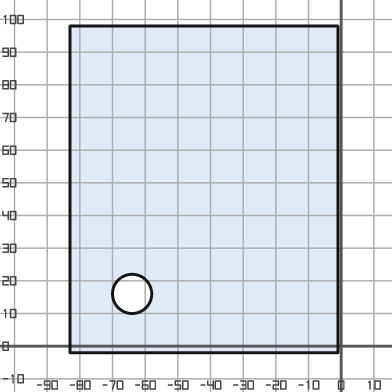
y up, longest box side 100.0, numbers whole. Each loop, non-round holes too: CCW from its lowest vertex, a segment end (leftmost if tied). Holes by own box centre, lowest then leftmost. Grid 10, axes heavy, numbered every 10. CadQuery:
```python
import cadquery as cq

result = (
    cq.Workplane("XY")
    .moveTo(-83.0, -2.0)
    .lineTo(-1.0, -2.0)
    .lineTo(-1.0, 98.0)
    .lineTo(-83.0, 98.0)
    .close()
    .moveTo(-64.0, 16.0)
    .circle(6.0)
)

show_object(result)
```